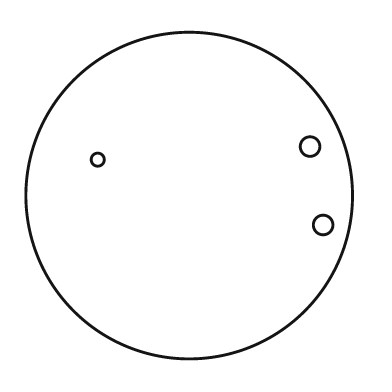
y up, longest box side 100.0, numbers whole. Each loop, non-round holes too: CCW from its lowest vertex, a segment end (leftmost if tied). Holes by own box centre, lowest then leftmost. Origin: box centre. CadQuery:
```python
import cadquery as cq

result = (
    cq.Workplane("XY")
    .moveTo(0.0, 0.0)
    .circle(50.0)
    .moveTo(41.0, -9.0)
    .circle(3.0)
    .moveTo(-28.0, 11.0)
    .circle(2.0)
    .moveTo(37.0, 15.0)
    .circle(3.0)
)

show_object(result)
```